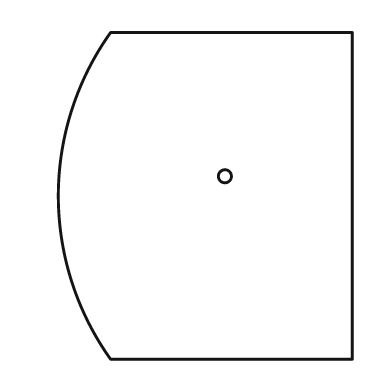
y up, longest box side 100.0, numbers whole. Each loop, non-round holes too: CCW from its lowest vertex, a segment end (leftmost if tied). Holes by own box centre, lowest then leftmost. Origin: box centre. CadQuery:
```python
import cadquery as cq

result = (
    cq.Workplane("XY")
    .moveTo(-29.0, -50.0)
    .lineTo(45.0, -50.0)
    .lineTo(45.0, 50.0)
    .lineTo(-29.0, 50.0)
    .threePointArc((-45.0, 0.0), (-29.0, -50.0))
    .close()
    .moveTo(6.0, 6.0)
    .circle(2.0)
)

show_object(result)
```